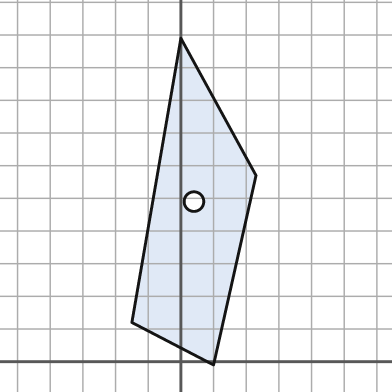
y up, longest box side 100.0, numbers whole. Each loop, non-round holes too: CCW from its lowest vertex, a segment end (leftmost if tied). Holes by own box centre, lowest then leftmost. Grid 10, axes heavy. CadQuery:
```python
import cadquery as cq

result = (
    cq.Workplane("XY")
    .moveTo(10.0, -1.0)
    .lineTo(23.0, 57.0)
    .lineTo(0.0, 99.0)
    .lineTo(-15.0, 12.0)
    .close()
    .moveTo(4.0, 49.0)
    .circle(3.0)
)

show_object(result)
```